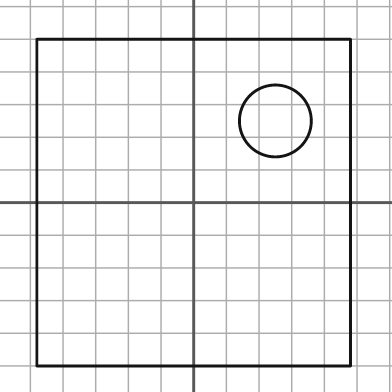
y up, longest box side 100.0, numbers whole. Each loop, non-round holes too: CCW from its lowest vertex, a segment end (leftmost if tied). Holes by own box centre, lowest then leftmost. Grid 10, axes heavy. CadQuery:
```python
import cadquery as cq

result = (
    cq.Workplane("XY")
    .moveTo(-48.0, -50.0)
    .lineTo(48.0, -50.0)
    .lineTo(48.0, 50.0)
    .lineTo(-48.0, 50.0)
    .close()
    .moveTo(25.0, 25.0)
    .circle(11.0)
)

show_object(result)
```